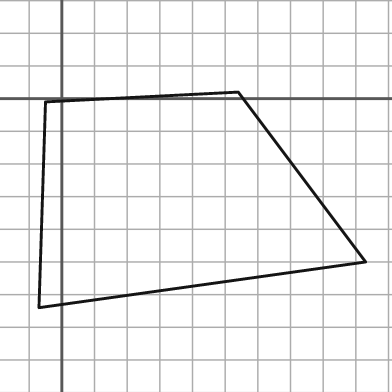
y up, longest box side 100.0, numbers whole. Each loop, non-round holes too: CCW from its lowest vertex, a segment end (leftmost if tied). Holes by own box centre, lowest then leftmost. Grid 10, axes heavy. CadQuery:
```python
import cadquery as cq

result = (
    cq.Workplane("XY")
    .moveTo(-7.0, -64.0)
    .lineTo(93.0, -50.0)
    .lineTo(54.0, 2.0)
    .lineTo(-5.0, -1.0)
    .close()
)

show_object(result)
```